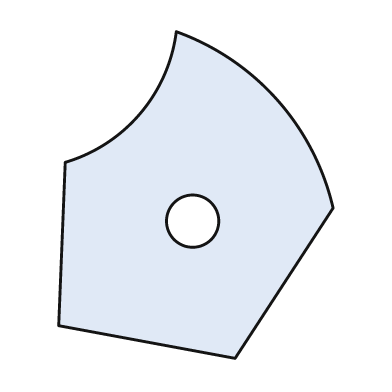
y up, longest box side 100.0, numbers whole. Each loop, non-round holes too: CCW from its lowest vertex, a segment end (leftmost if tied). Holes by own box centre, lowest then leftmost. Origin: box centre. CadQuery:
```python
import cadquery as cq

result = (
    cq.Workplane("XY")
    .moveTo(12.0, -50.0)
    .lineTo(42.0, -4.0)
    .threePointArc((25.0, 29.0), (-6.0, 50.0))
    .threePointArc((-17.0, 25.0), (-40.0, 10.0))
    .lineTo(-42.0, -40.0)
    .close()
    .moveTo(-1.0, -8.0)
    .circle(8.0)
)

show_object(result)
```